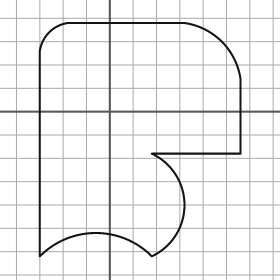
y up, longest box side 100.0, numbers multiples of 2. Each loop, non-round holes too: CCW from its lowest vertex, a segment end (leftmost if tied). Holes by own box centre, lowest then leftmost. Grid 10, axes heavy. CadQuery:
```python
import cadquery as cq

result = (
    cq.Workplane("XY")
    .moveTo(-30.0, -62.0)
    .threePointArc((-6.0, -52.0), (18.0, -62.0))
    .threePointArc((32.0, -40.0), (18.0, -18.0))
    .lineTo(56.0, -18.0)
    .lineTo(56.0, 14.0)
    .threePointArc((48.0, 30.0), (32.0, 38.0))
    .lineTo(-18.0, 38.0)
    .threePointArc((-26.0, 34.0), (-30.0, 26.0))
    .close()
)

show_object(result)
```